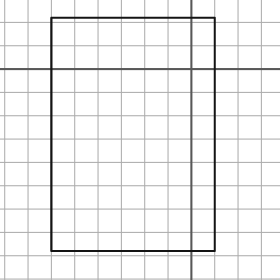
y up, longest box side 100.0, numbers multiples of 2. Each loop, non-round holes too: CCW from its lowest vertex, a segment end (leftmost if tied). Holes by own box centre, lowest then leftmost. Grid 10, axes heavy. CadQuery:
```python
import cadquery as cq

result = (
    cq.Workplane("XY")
    .moveTo(-60.0, -78.0)
    .lineTo(10.0, -78.0)
    .lineTo(10.0, 22.0)
    .lineTo(-60.0, 22.0)
    .close()
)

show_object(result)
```